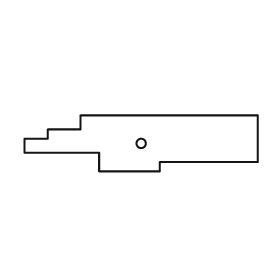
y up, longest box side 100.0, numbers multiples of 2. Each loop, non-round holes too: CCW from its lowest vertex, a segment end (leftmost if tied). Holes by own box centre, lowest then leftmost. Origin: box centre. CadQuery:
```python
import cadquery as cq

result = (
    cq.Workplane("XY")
    .moveTo(-18.0, -12.0)
    .lineTo(8.0, -12.0)
    .lineTo(8.0, -8.0)
    .lineTo(50.0, -8.0)
    .lineTo(50.0, 12.0)
    .lineTo(-26.0, 12.0)
    .lineTo(-26.0, 6.0)
    .lineTo(-40.0, 6.0)
    .lineTo(-40.0, 2.0)
    .lineTo(-50.0, 2.0)
    .lineTo(-50.0, -4.0)
    .lineTo(-18.0, -4.0)
    .close()
    .moveTo(0.0, 0.0)
    .circle(2.0)
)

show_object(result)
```